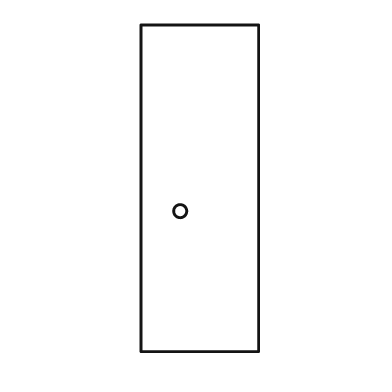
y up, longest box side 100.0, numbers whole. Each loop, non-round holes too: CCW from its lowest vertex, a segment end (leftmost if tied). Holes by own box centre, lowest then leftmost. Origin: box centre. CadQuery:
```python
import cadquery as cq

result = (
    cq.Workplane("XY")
    .moveTo(-18.0, -50.0)
    .lineTo(18.0, -50.0)
    .lineTo(18.0, 50.0)
    .lineTo(-18.0, 50.0)
    .close()
    .moveTo(-6.0, -7.0)
    .circle(2.0)
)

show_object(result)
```